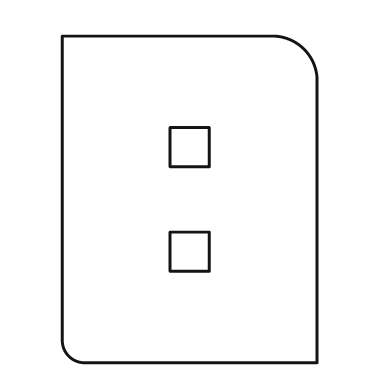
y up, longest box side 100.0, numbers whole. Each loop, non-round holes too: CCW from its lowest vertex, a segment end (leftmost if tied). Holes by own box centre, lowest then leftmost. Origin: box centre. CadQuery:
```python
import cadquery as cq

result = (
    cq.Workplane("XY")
    .moveTo(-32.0, -50.0)
    .lineTo(39.0, -50.0)
    .lineTo(39.0, 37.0)
    .threePointArc((35.0, 46.0), (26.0, 50.0))
    .lineTo(-39.0, 50.0)
    .lineTo(-39.0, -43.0)
    .threePointArc((-37.0, -48.0), (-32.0, -50.0))
    .close()
    .moveTo(-6.0, -22.0)
    .lineTo(6.0, -22.0)
    .lineTo(6.0, -10.0)
    .lineTo(-6.0, -10.0)
    .close()
    .moveTo(-6.0, 10.0)
    .lineTo(6.0, 10.0)
    .lineTo(6.0, 22.0)
    .lineTo(-6.0, 22.0)
    .close()
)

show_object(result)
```